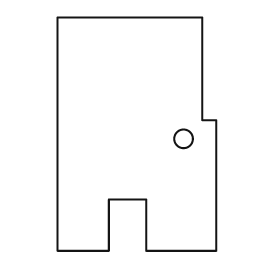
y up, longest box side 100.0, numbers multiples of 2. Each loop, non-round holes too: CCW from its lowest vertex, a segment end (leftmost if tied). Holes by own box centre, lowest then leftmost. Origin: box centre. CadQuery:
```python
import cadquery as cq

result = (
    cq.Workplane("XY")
    .moveTo(-34.0, -50.0)
    .lineTo(-12.0, -50.0)
    .lineTo(-12.0, -28.0)
    .lineTo(4.0, -28.0)
    .lineTo(4.0, -50.0)
    .lineTo(34.0, -50.0)
    .lineTo(34.0, 6.0)
    .lineTo(28.0, 6.0)
    .lineTo(28.0, 50.0)
    .lineTo(-34.0, 50.0)
    .close()
    .moveTo(20.0, -2.0)
    .circle(4.0)
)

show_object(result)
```